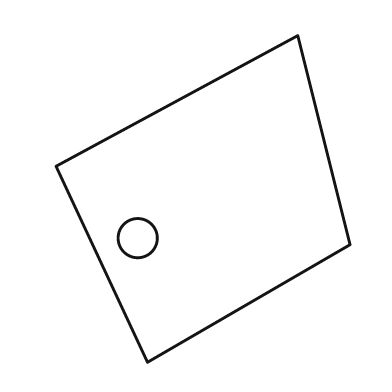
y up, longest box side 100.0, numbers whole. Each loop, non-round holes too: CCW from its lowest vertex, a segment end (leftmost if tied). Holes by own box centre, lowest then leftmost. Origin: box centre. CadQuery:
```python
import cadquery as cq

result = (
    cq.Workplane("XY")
    .moveTo(-17.0, -50.0)
    .lineTo(45.0, -14.0)
    .lineTo(29.0, 50.0)
    .lineTo(-45.0, 10.0)
    .close()
    .moveTo(-20.0, -12.0)
    .circle(6.0)
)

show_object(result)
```